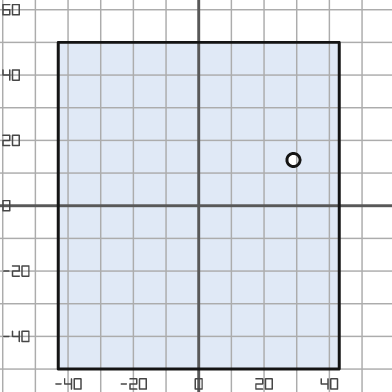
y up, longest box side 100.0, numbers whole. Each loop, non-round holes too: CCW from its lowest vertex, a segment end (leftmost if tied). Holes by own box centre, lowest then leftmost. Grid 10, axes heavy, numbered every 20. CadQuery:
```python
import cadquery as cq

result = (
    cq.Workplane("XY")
    .moveTo(-43.0, -50.0)
    .lineTo(43.0, -50.0)
    .lineTo(43.0, 50.0)
    .lineTo(-43.0, 50.0)
    .close()
    .moveTo(29.0, 14.0)
    .circle(2.0)
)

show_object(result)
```